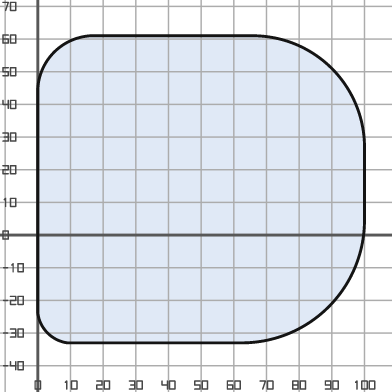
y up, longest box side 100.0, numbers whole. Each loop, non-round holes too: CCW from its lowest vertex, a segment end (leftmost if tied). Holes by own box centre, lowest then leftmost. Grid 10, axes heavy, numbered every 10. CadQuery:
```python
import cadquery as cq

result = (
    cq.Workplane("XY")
    .moveTo(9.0, -33.0)
    .lineTo(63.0, -33.0)
    .threePointArc((89.0, -22.0), (100.0, 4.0))
    .lineTo(100.0, 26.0)
    .threePointArc((90.0, 51.0), (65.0, 61.0))
    .lineTo(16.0, 61.0)
    .threePointArc((5.0, 56.0), (0.0, 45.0))
    .lineTo(0.0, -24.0)
    .threePointArc((3.0, -30.0), (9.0, -33.0))
    .close()
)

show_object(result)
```